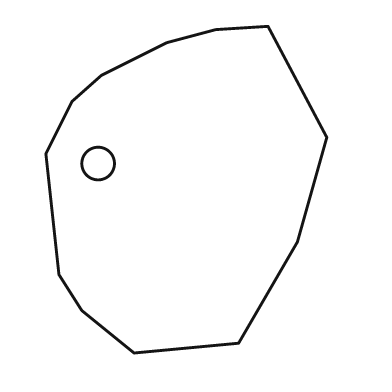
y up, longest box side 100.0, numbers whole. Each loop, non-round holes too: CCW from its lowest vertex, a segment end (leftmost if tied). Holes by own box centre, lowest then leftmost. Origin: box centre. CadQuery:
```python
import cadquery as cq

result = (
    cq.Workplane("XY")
    .moveTo(-16.0, -50.0)
    .lineTo(16.0, -47.0)
    .lineTo(34.0, -16.0)
    .lineTo(43.0, 16.0)
    .lineTo(25.0, 50.0)
    .lineTo(9.0, 49.0)
    .lineTo(-6.0, 45.0)
    .lineTo(-26.0, 35.0)
    .lineTo(-35.0, 27.0)
    .lineTo(-43.0, 11.0)
    .lineTo(-39.0, -26.0)
    .lineTo(-32.0, -37.0)
    .close()
    .moveTo(-27.0, 8.0)
    .circle(5.0)
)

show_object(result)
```